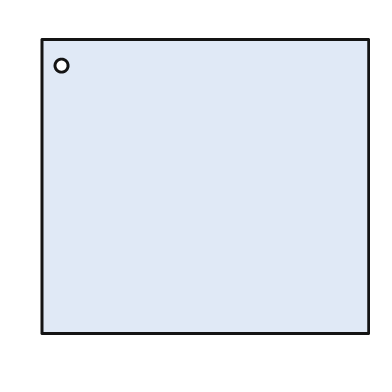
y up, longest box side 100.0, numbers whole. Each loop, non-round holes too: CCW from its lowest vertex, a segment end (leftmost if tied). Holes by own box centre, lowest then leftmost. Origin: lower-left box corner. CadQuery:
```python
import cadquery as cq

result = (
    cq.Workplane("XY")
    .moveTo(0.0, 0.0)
    .lineTo(100.0, 0.0)
    .lineTo(100.0, 90.0)
    .lineTo(0.0, 90.0)
    .close()
    .moveTo(6.0, 82.0)
    .circle(2.0)
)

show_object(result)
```